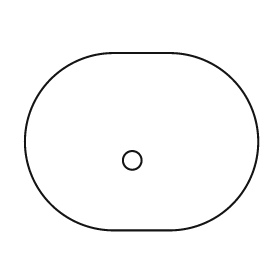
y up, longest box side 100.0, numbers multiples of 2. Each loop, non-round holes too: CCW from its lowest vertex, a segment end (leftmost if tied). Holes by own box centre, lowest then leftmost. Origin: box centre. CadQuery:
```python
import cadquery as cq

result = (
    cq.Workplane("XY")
    .moveTo(-12.0, -38.0)
    .lineTo(12.0, -38.0)
    .threePointArc((50.0, 0.0), (12.0, 38.0))
    .lineTo(-12.0, 38.0)
    .threePointArc((-50.0, 0.0), (-12.0, -38.0))
    .close()
    .moveTo(-4.0, -8.0)
    .circle(4.0)
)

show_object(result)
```